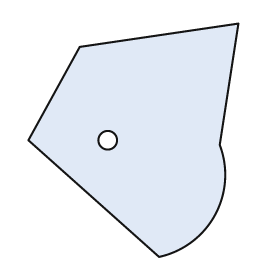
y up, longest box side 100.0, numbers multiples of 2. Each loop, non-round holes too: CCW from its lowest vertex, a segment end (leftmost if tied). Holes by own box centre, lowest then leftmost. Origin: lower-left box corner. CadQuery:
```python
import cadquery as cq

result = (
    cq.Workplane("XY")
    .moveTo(56.0, 0.0)
    .threePointArc((80.0, 18.0), (82.0, 48.0))
    .lineTo(90.0, 100.0)
    .lineTo(22.0, 90.0)
    .lineTo(0.0, 50.0)
    .close()
    .moveTo(34.0, 50.0)
    .circle(4.0)
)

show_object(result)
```